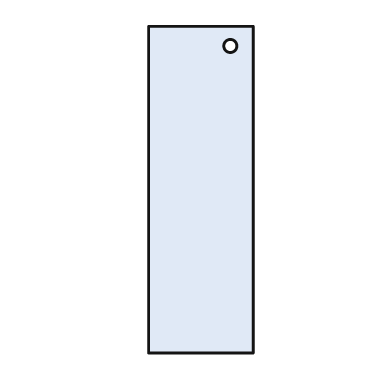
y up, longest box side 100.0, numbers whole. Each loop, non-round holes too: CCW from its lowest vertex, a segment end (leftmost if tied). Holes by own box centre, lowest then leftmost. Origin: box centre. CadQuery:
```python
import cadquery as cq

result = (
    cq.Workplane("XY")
    .moveTo(-16.0, -50.0)
    .lineTo(16.0, -50.0)
    .lineTo(16.0, 50.0)
    .lineTo(-16.0, 50.0)
    .close()
    .moveTo(9.0, 44.0)
    .circle(2.0)
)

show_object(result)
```